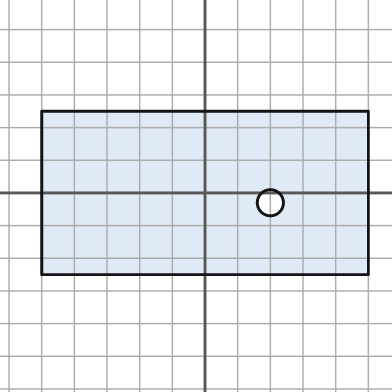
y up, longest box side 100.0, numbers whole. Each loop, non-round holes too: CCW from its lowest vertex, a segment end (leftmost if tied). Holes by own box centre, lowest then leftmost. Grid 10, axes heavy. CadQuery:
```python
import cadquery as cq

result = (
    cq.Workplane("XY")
    .moveTo(-50.0, -25.0)
    .lineTo(50.0, -25.0)
    .lineTo(50.0, 25.0)
    .lineTo(-50.0, 25.0)
    .close()
    .moveTo(20.0, -3.0)
    .circle(4.0)
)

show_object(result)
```